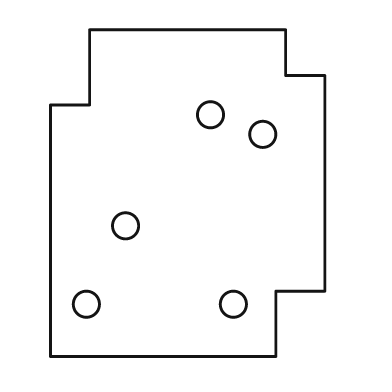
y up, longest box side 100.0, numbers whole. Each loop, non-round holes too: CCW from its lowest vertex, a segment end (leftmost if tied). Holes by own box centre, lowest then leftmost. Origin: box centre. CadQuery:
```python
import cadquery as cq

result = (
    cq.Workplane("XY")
    .moveTo(-42.0, -50.0)
    .lineTo(27.0, -50.0)
    .lineTo(27.0, -30.0)
    .lineTo(42.0, -30.0)
    .lineTo(42.0, 36.0)
    .lineTo(30.0, 36.0)
    .lineTo(30.0, 50.0)
    .lineTo(-30.0, 50.0)
    .lineTo(-30.0, 27.0)
    .lineTo(-42.0, 27.0)
    .close()
    .moveTo(-31.0, -34.0)
    .circle(4.0)
    .moveTo(14.0, -34.0)
    .circle(4.0)
    .moveTo(-19.0, -10.0)
    .circle(4.0)
    .moveTo(23.0, 18.0)
    .circle(4.0)
    .moveTo(7.0, 24.0)
    .circle(4.0)
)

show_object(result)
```